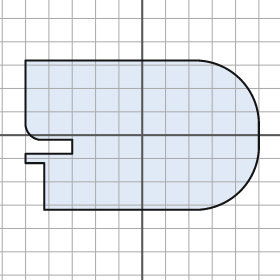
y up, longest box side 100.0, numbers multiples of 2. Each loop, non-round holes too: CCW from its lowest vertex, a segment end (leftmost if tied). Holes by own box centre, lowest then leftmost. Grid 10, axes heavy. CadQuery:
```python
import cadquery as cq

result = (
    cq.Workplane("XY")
    .moveTo(-42.0, -32.0)
    .lineTo(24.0, -32.0)
    .threePointArc((42.0, -24.0), (50.0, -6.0))
    .lineTo(50.0, 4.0)
    .threePointArc((42.0, 24.0), (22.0, 32.0))
    .lineTo(-50.0, 32.0)
    .lineTo(-50.0, 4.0)
    .threePointArc((-48.0, 0.0), (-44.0, -2.0))
    .lineTo(-30.0, -2.0)
    .lineTo(-30.0, -8.0)
    .lineTo(-50.0, -8.0)
    .lineTo(-50.0, -12.0)
    .lineTo(-42.0, -12.0)
    .close()
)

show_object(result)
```